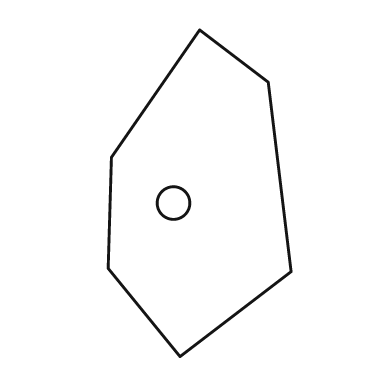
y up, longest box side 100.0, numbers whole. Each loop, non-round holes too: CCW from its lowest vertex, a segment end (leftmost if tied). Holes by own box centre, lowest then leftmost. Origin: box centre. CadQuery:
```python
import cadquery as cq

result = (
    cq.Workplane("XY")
    .moveTo(-6.0, -50.0)
    .lineTo(28.0, -24.0)
    .lineTo(21.0, 34.0)
    .lineTo(0.0, 50.0)
    .lineTo(-27.0, 11.0)
    .lineTo(-28.0, -23.0)
    .close()
    .moveTo(-8.0, -3.0)
    .circle(5.0)
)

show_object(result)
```